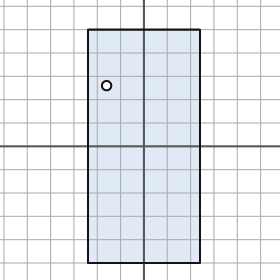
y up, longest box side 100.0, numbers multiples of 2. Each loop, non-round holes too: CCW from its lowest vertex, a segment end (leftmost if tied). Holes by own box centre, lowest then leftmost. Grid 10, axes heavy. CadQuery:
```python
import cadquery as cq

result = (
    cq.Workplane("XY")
    .moveTo(-24.0, -50.0)
    .lineTo(24.0, -50.0)
    .lineTo(24.0, 50.0)
    .lineTo(-24.0, 50.0)
    .close()
    .moveTo(-16.0, 26.0)
    .circle(2.0)
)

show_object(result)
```